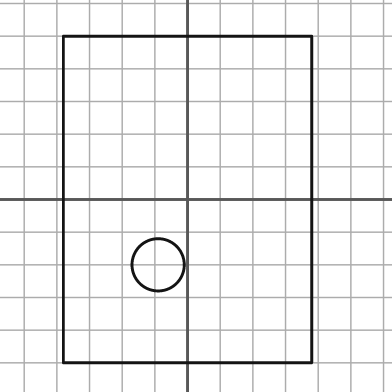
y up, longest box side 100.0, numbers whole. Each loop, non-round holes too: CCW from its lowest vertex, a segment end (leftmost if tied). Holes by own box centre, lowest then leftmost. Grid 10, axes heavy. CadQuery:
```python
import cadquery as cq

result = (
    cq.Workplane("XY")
    .moveTo(-38.0, -50.0)
    .lineTo(38.0, -50.0)
    .lineTo(38.0, 50.0)
    .lineTo(-38.0, 50.0)
    .close()
    .moveTo(-9.0, -20.0)
    .circle(8.0)
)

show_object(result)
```